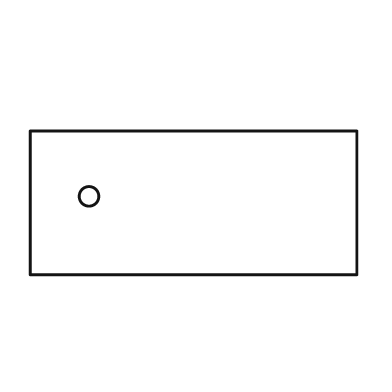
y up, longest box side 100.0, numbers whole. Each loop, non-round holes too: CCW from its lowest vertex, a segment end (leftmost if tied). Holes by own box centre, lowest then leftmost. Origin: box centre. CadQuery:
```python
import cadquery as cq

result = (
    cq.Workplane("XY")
    .moveTo(-50.0, -22.0)
    .lineTo(50.0, -22.0)
    .lineTo(50.0, 22.0)
    .lineTo(-50.0, 22.0)
    .close()
    .moveTo(-32.0, 2.0)
    .circle(3.0)
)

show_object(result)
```